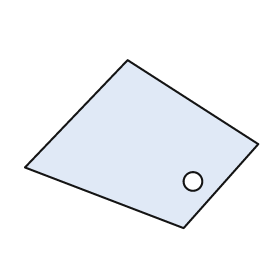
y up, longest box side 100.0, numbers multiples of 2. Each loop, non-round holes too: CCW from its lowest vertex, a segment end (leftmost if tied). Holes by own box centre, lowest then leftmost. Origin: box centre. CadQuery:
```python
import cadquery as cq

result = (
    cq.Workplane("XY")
    .moveTo(18.0, -36.0)
    .lineTo(50.0, 0.0)
    .lineTo(-6.0, 36.0)
    .lineTo(-50.0, -10.0)
    .close()
    .moveTo(22.0, -16.0)
    .circle(4.0)
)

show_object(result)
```